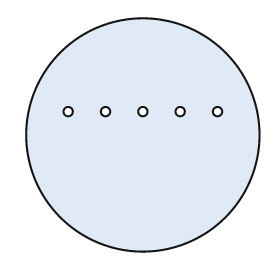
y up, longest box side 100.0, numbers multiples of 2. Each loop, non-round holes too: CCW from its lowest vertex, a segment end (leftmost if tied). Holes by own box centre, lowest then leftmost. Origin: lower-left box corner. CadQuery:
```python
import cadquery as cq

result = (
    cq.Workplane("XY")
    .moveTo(50.0, 50.0)
    .circle(50.0)
    .moveTo(18.0, 60.0)
    .circle(2.0)
    .moveTo(34.0, 60.0)
    .circle(2.0)
    .moveTo(50.0, 60.0)
    .circle(2.0)
    .moveTo(66.0, 60.0)
    .circle(2.0)
    .moveTo(82.0, 60.0)
    .circle(2.0)
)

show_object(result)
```